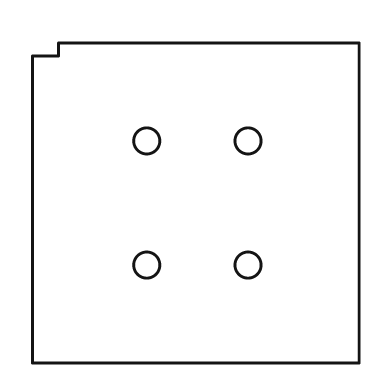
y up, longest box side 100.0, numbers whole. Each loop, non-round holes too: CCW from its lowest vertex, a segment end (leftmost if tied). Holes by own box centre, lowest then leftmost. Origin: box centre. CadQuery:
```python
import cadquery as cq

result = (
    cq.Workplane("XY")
    .moveTo(-50.0, -49.0)
    .lineTo(50.0, -49.0)
    .lineTo(50.0, 49.0)
    .lineTo(-42.0, 49.0)
    .lineTo(-42.0, 45.0)
    .lineTo(-50.0, 45.0)
    .close()
    .moveTo(-15.0, -19.0)
    .circle(4.0)
    .moveTo(16.0, -19.0)
    .circle(4.0)
    .moveTo(-15.0, 19.0)
    .circle(4.0)
    .moveTo(16.0, 19.0)
    .circle(4.0)
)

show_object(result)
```